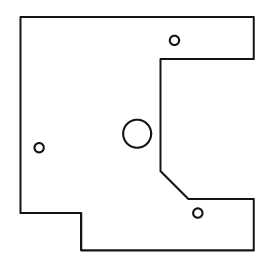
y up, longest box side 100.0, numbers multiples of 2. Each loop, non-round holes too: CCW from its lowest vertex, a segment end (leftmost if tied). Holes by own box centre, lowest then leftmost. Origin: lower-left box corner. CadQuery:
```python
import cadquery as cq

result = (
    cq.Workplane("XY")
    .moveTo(26.0, 0.0)
    .lineTo(100.0, 0.0)
    .lineTo(100.0, 22.0)
    .lineTo(72.0, 22.0)
    .lineTo(60.0, 34.0)
    .lineTo(60.0, 82.0)
    .lineTo(100.0, 82.0)
    .lineTo(100.0, 100.0)
    .lineTo(0.0, 100.0)
    .lineTo(0.0, 16.0)
    .lineTo(26.0, 16.0)
    .close()
    .moveTo(76.0, 16.0)
    .circle(2.0)
    .moveTo(8.0, 44.0)
    .circle(2.0)
    .moveTo(50.0, 50.0)
    .circle(6.0)
    .moveTo(66.0, 90.0)
    .circle(2.0)
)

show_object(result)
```